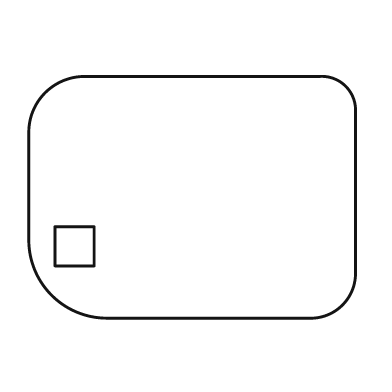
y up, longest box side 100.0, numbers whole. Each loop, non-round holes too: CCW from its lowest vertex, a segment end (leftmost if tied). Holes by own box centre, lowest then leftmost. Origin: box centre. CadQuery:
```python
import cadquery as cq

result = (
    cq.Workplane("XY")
    .moveTo(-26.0, -37.0)
    .lineTo(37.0, -37.0)
    .threePointArc((46.0, -33.0), (50.0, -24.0))
    .lineTo(50.0, 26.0)
    .threePointArc((47.0, 34.0), (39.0, 37.0))
    .lineTo(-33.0, 37.0)
    .threePointArc((-45.0, 32.0), (-50.0, 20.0))
    .lineTo(-50.0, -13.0)
    .threePointArc((-43.0, -30.0), (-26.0, -37.0))
    .close()
    .moveTo(-42.0, -21.0)
    .lineTo(-30.0, -21.0)
    .lineTo(-30.0, -9.0)
    .lineTo(-42.0, -9.0)
    .close()
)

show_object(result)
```